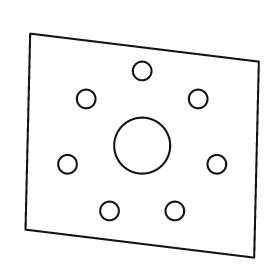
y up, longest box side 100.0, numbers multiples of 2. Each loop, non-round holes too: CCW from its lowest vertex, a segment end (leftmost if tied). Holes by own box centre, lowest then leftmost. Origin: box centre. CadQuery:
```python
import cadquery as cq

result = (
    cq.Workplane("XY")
    .moveTo(48.0, -48.0)
    .lineTo(50.0, 36.0)
    .lineTo(-48.0, 48.0)
    .lineTo(-50.0, -36.0)
    .close()
    .moveTo(-14.0, -28.0)
    .circle(4.0)
    .moveTo(14.0, -28.0)
    .circle(4.0)
    .moveTo(-32.0, -8.0)
    .circle(4.0)
    .moveTo(32.0, -8.0)
    .circle(4.0)
    .moveTo(0.0, 0.0)
    .circle(12.0)
    .moveTo(-24.0, 20.0)
    .circle(4.0)
    .moveTo(24.0, 20.0)
    .circle(4.0)
    .moveTo(0.0, 32.0)
    .circle(4.0)
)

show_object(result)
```